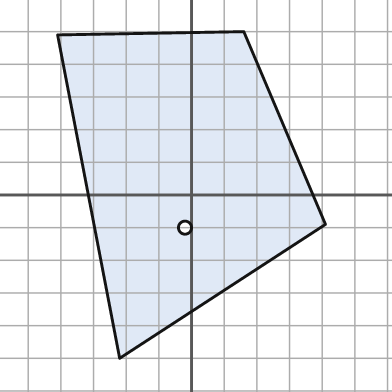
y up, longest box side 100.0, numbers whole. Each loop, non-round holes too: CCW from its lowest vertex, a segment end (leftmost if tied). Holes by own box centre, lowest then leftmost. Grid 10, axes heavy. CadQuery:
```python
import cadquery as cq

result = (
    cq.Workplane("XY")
    .moveTo(-22.0, -50.0)
    .lineTo(41.0, -9.0)
    .lineTo(16.0, 50.0)
    .lineTo(-41.0, 49.0)
    .close()
    .moveTo(-2.0, -10.0)
    .circle(2.0)
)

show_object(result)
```